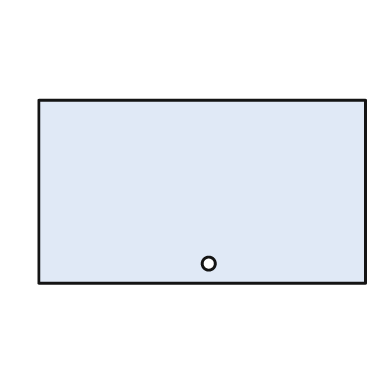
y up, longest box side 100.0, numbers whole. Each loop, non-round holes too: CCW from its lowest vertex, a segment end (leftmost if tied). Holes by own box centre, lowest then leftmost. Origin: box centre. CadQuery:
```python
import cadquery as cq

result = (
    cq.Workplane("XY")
    .moveTo(-50.0, -28.0)
    .lineTo(50.0, -28.0)
    .lineTo(50.0, 28.0)
    .lineTo(-50.0, 28.0)
    .close()
    .moveTo(2.0, -22.0)
    .circle(2.0)
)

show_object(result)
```